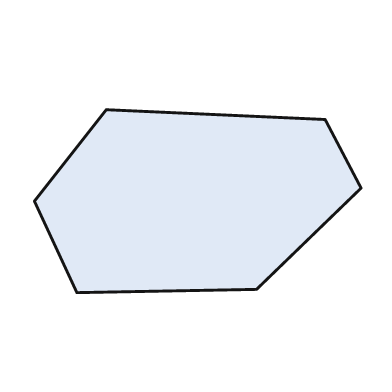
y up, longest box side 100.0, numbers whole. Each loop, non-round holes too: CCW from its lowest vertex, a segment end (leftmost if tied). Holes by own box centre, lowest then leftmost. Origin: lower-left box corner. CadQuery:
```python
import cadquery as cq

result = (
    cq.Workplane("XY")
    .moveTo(13.0, 0.0)
    .lineTo(68.0, 1.0)
    .lineTo(100.0, 32.0)
    .lineTo(89.0, 53.0)
    .lineTo(22.0, 56.0)
    .lineTo(0.0, 28.0)
    .close()
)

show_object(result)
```